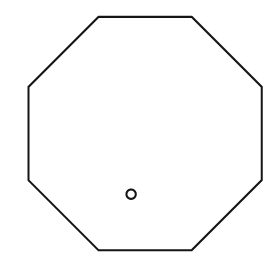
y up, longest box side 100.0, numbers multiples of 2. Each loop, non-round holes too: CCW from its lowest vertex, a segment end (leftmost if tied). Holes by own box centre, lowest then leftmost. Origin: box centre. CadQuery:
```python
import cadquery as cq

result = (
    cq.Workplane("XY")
    .moveTo(-20.0, -50.0)
    .lineTo(20.0, -50.0)
    .lineTo(50.0, -20.0)
    .lineTo(50.0, 20.0)
    .lineTo(20.0, 50.0)
    .lineTo(-20.0, 50.0)
    .lineTo(-50.0, 20.0)
    .lineTo(-50.0, -20.0)
    .close()
    .moveTo(-6.0, -26.0)
    .circle(2.0)
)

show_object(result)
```